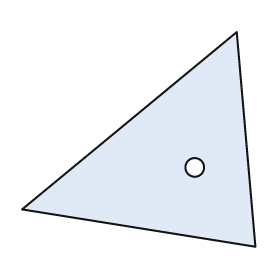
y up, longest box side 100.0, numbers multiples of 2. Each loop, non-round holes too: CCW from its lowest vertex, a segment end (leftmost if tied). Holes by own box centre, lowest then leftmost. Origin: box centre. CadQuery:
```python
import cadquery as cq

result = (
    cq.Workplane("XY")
    .moveTo(50.0, -46.0)
    .lineTo(42.0, 46.0)
    .lineTo(-50.0, -30.0)
    .close()
    .moveTo(24.0, -12.0)
    .circle(4.0)
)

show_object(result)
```